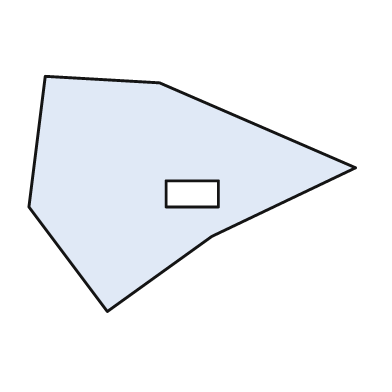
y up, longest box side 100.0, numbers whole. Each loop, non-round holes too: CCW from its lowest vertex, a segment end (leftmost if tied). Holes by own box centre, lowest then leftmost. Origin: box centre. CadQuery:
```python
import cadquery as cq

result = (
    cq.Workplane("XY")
    .moveTo(-26.0, -36.0)
    .lineTo(6.0, -13.0)
    .lineTo(50.0, 8.0)
    .lineTo(-10.0, 34.0)
    .lineTo(-45.0, 36.0)
    .lineTo(-50.0, -4.0)
    .close()
    .moveTo(-8.0, -4.0)
    .lineTo(8.0, -4.0)
    .lineTo(8.0, 4.0)
    .lineTo(-8.0, 4.0)
    .close()
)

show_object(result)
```